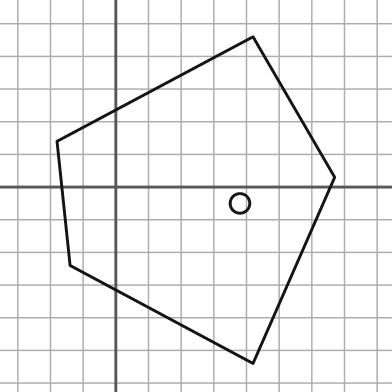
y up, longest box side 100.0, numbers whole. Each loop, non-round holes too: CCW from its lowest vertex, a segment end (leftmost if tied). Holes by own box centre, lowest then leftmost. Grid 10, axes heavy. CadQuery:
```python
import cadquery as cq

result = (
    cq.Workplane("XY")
    .moveTo(42.0, -54.0)
    .lineTo(67.0, 3.0)
    .lineTo(42.0, 46.0)
    .lineTo(-18.0, 14.0)
    .lineTo(-14.0, -24.0)
    .close()
    .moveTo(38.0, -5.0)
    .circle(3.0)
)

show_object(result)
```